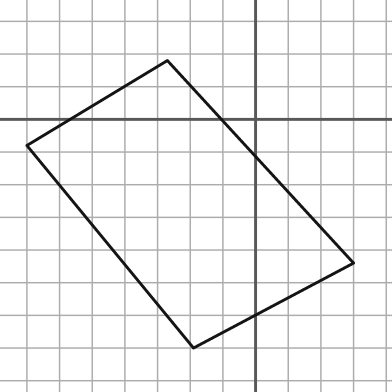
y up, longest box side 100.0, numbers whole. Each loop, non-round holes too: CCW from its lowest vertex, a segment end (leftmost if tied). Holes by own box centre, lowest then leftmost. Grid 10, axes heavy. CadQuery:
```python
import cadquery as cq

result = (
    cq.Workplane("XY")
    .moveTo(-19.0, -70.0)
    .lineTo(30.0, -44.0)
    .lineTo(-27.0, 18.0)
    .lineTo(-70.0, -8.0)
    .close()
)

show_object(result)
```